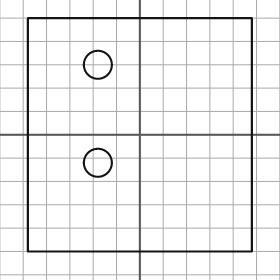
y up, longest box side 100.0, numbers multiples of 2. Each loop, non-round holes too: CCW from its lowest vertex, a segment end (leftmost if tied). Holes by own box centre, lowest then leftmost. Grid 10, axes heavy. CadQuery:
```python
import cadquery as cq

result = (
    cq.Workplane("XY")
    .moveTo(-48.0, -50.0)
    .lineTo(48.0, -50.0)
    .lineTo(48.0, 50.0)
    .lineTo(-48.0, 50.0)
    .close()
    .moveTo(-18.0, -12.0)
    .circle(6.0)
    .moveTo(-18.0, 30.0)
    .circle(6.0)
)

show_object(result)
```